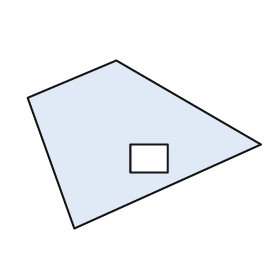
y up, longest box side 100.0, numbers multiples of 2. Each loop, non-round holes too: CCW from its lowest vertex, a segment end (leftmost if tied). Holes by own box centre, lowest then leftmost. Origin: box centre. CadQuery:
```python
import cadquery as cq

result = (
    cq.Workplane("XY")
    .moveTo(-30.0, -36.0)
    .lineTo(50.0, 0.0)
    .lineTo(-12.0, 36.0)
    .lineTo(-50.0, 20.0)
    .close()
    .moveTo(-6.0, -12.0)
    .lineTo(10.0, -12.0)
    .lineTo(10.0, 0.0)
    .lineTo(-6.0, 0.0)
    .close()
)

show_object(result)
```